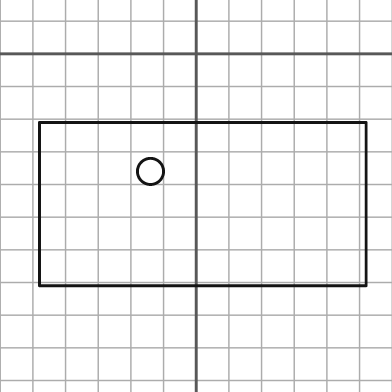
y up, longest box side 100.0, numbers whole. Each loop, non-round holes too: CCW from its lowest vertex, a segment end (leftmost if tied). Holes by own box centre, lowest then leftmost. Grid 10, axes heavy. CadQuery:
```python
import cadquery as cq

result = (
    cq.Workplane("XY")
    .moveTo(-48.0, -71.0)
    .lineTo(52.0, -71.0)
    .lineTo(52.0, -21.0)
    .lineTo(-48.0, -21.0)
    .close()
    .moveTo(-14.0, -36.0)
    .circle(4.0)
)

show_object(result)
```